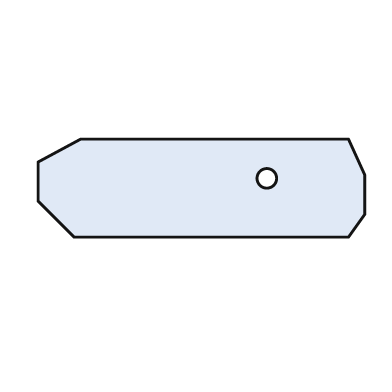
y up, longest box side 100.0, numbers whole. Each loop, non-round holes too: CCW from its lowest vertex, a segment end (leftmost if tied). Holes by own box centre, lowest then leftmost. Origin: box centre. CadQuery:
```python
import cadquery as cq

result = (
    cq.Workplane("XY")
    .moveTo(-39.0, -15.0)
    .lineTo(45.0, -15.0)
    .lineTo(50.0, -8.0)
    .lineTo(50.0, 4.0)
    .lineTo(45.0, 15.0)
    .lineTo(-37.0, 15.0)
    .lineTo(-50.0, 8.0)
    .lineTo(-50.0, -4.0)
    .close()
    .moveTo(20.0, 3.0)
    .circle(3.0)
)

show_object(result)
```